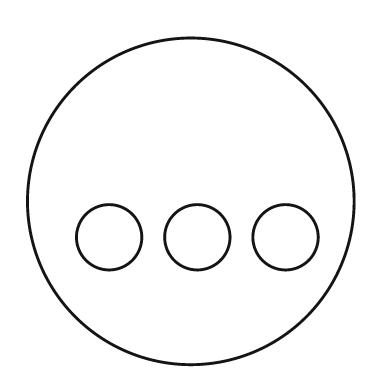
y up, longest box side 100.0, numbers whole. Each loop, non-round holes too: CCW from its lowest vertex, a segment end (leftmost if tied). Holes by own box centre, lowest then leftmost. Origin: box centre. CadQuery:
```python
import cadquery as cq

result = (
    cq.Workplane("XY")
    .moveTo(0.0, 0.0)
    .circle(50.0)
    .moveTo(-25.0, -11.0)
    .circle(10.0)
    .moveTo(2.0, -11.0)
    .circle(10.0)
    .moveTo(29.0, -11.0)
    .circle(10.0)
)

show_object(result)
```